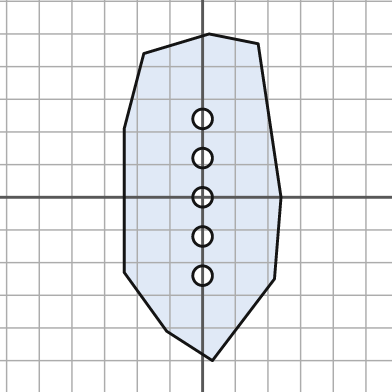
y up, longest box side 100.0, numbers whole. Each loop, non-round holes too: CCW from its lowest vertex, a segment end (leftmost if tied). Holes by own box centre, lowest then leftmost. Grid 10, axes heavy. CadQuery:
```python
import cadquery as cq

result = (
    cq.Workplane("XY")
    .moveTo(3.0, -50.0)
    .lineTo(22.0, -25.0)
    .lineTo(24.0, 0.0)
    .lineTo(17.0, 47.0)
    .lineTo(2.0, 50.0)
    .lineTo(-18.0, 44.0)
    .lineTo(-24.0, 21.0)
    .lineTo(-24.0, -23.0)
    .lineTo(-11.0, -41.0)
    .close()
    .moveTo(0.0, -24.0)
    .circle(3.0)
    .moveTo(0.0, -12.0)
    .circle(3.0)
    .moveTo(0.0, 0.0)
    .circle(3.0)
    .moveTo(0.0, 12.0)
    .circle(3.0)
    .moveTo(0.0, 24.0)
    .circle(3.0)
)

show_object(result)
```